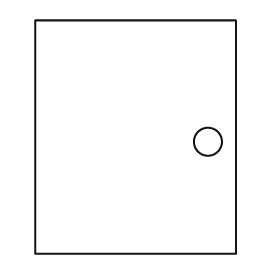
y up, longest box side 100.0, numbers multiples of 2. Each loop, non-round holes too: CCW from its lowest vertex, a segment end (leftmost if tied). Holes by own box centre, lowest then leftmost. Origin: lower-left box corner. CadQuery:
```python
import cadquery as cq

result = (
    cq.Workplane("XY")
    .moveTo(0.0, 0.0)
    .lineTo(86.0, 0.0)
    .lineTo(86.0, 100.0)
    .lineTo(0.0, 100.0)
    .close()
    .moveTo(74.0, 48.0)
    .circle(6.0)
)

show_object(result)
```